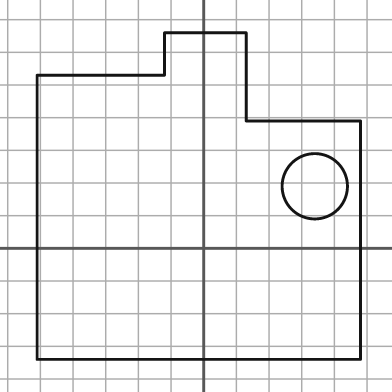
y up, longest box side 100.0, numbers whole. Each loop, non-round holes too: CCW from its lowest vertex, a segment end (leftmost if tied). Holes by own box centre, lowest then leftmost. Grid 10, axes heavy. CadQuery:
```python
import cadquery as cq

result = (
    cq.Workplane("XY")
    .moveTo(-51.0, -34.0)
    .lineTo(48.0, -34.0)
    .lineTo(48.0, 39.0)
    .lineTo(13.0, 39.0)
    .lineTo(13.0, 66.0)
    .lineTo(-12.0, 66.0)
    .lineTo(-12.0, 53.0)
    .lineTo(-51.0, 53.0)
    .close()
    .moveTo(34.0, 19.0)
    .circle(10.0)
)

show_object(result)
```